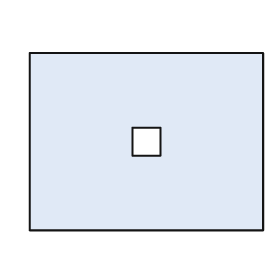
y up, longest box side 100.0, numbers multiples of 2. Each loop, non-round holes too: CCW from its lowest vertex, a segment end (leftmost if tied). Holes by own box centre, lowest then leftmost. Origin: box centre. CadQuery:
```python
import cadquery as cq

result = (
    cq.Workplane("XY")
    .moveTo(-50.0, -38.0)
    .lineTo(50.0, -38.0)
    .lineTo(50.0, 38.0)
    .lineTo(-50.0, 38.0)
    .close()
    .moveTo(-6.0, -6.0)
    .lineTo(6.0, -6.0)
    .lineTo(6.0, 6.0)
    .lineTo(-6.0, 6.0)
    .close()
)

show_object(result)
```